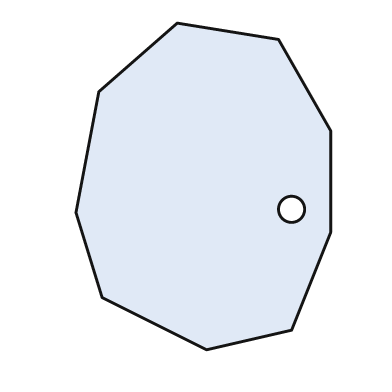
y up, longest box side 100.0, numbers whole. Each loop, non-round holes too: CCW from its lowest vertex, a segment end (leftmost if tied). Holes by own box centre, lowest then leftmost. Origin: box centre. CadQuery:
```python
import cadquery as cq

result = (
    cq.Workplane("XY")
    .moveTo(1.0, -50.0)
    .lineTo(27.0, -44.0)
    .lineTo(39.0, -14.0)
    .lineTo(39.0, 17.0)
    .lineTo(23.0, 45.0)
    .lineTo(-8.0, 50.0)
    .lineTo(-32.0, 29.0)
    .lineTo(-39.0, -8.0)
    .lineTo(-31.0, -34.0)
    .close()
    .moveTo(27.0, -7.0)
    .circle(4.0)
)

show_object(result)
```